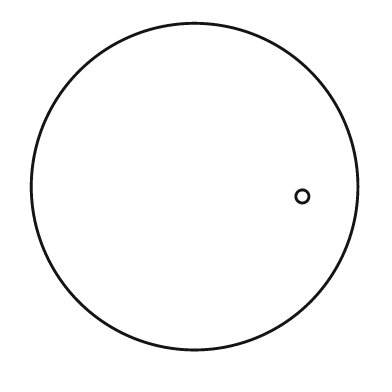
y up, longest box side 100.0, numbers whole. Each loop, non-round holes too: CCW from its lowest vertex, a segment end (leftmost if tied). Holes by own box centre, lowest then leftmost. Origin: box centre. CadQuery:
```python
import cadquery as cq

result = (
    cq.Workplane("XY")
    .moveTo(0.0, 0.0)
    .circle(50.0)
    .moveTo(33.0, -3.0)
    .circle(2.0)
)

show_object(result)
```